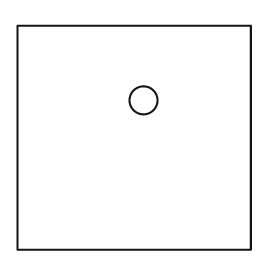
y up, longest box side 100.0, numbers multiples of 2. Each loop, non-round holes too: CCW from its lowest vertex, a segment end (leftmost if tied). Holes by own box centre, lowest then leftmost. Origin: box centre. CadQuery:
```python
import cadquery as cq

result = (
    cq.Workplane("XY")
    .moveTo(-50.0, -48.0)
    .lineTo(50.0, -48.0)
    .lineTo(50.0, 48.0)
    .lineTo(-50.0, 48.0)
    .close()
    .moveTo(4.0, 16.0)
    .circle(6.0)
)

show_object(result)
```